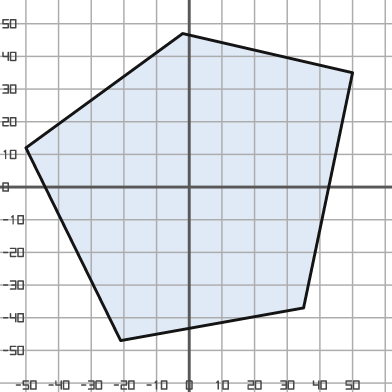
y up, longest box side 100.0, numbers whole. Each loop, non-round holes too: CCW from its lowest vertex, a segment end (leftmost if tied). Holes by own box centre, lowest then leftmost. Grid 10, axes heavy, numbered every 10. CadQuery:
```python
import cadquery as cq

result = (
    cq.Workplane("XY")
    .moveTo(-21.0, -47.0)
    .lineTo(35.0, -37.0)
    .lineTo(50.0, 35.0)
    .lineTo(-2.0, 47.0)
    .lineTo(-50.0, 12.0)
    .close()
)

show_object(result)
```